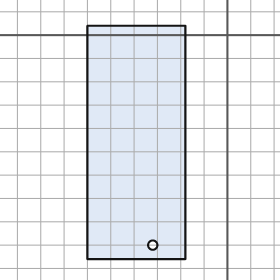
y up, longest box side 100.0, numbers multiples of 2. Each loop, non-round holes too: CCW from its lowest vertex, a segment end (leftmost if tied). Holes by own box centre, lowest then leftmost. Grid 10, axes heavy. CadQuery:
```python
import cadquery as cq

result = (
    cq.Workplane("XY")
    .moveTo(-60.0, -96.0)
    .lineTo(-18.0, -96.0)
    .lineTo(-18.0, 4.0)
    .lineTo(-60.0, 4.0)
    .close()
    .moveTo(-32.0, -90.0)
    .circle(2.0)
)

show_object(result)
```